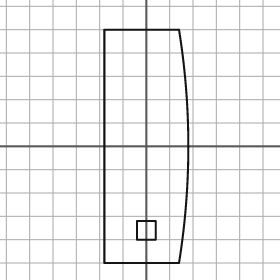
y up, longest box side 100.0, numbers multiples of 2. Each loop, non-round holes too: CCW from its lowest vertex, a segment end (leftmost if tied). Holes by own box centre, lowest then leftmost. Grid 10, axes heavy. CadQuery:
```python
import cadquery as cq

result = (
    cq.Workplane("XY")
    .moveTo(-18.0, -50.0)
    .lineTo(14.0, -50.0)
    .threePointArc((18.0, 0.0), (14.0, 50.0))
    .lineTo(-18.0, 50.0)
    .close()
    .moveTo(-4.0, -40.0)
    .lineTo(4.0, -40.0)
    .lineTo(4.0, -32.0)
    .lineTo(-4.0, -32.0)
    .close()
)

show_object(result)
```